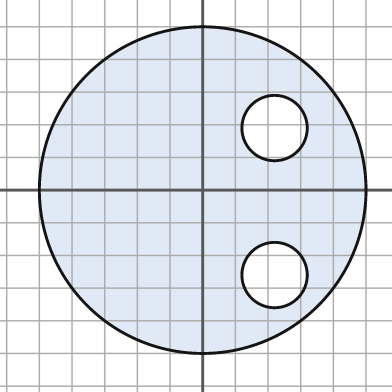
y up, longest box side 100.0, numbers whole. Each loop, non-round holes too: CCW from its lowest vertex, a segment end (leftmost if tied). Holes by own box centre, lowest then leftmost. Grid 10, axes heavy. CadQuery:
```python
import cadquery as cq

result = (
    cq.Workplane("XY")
    .moveTo(0.0, 0.0)
    .circle(50.0)
    .moveTo(22.0, -26.0)
    .circle(10.0)
    .moveTo(22.0, 19.0)
    .circle(10.0)
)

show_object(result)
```